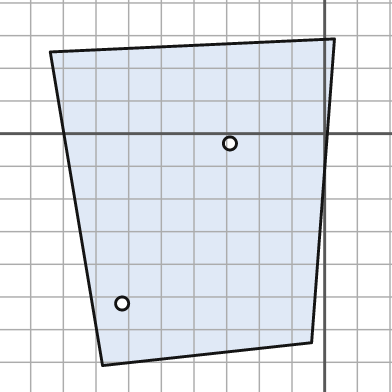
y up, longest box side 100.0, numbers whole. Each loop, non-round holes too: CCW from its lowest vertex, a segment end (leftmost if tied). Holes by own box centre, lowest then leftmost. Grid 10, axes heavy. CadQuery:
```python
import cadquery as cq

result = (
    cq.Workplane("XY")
    .moveTo(-68.0, -71.0)
    .lineTo(-4.0, -64.0)
    .lineTo(3.0, 29.0)
    .lineTo(-84.0, 25.0)
    .close()
    .moveTo(-62.0, -52.0)
    .circle(2.0)
    .moveTo(-29.0, -3.0)
    .circle(2.0)
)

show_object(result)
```